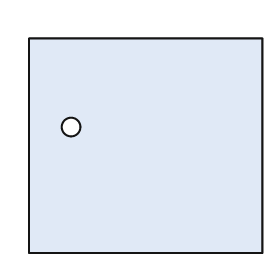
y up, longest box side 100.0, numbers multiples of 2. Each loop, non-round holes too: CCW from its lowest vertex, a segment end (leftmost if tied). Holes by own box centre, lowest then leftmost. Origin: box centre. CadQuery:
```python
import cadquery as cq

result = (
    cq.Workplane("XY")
    .moveTo(-50.0, -46.0)
    .lineTo(50.0, -46.0)
    .lineTo(50.0, 46.0)
    .lineTo(-50.0, 46.0)
    .close()
    .moveTo(-32.0, 8.0)
    .circle(4.0)
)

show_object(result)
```